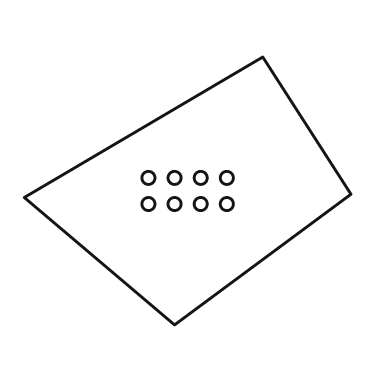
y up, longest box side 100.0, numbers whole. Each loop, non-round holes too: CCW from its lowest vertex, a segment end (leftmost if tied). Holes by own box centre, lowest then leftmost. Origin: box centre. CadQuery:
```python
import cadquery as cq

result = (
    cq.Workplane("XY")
    .moveTo(-4.0, -41.0)
    .lineTo(50.0, -1.0)
    .lineTo(23.0, 41.0)
    .lineTo(-50.0, -2.0)
    .close()
    .moveTo(-12.0, -4.0)
    .circle(2.0)
    .moveTo(-4.0, -4.0)
    .circle(2.0)
    .moveTo(4.0, -4.0)
    .circle(2.0)
    .moveTo(12.0, -4.0)
    .circle(2.0)
    .moveTo(-12.0, 4.0)
    .circle(2.0)
    .moveTo(-4.0, 4.0)
    .circle(2.0)
    .moveTo(4.0, 4.0)
    .circle(2.0)
    .moveTo(12.0, 4.0)
    .circle(2.0)
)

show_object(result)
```